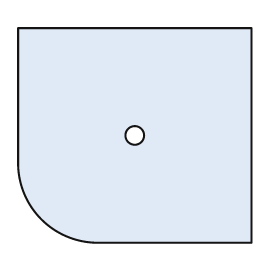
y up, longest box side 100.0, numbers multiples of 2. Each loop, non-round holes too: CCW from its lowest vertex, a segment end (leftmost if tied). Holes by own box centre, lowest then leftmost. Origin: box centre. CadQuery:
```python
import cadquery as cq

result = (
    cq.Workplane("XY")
    .moveTo(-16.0, -46.0)
    .lineTo(50.0, -46.0)
    .lineTo(50.0, 46.0)
    .lineTo(-50.0, 46.0)
    .lineTo(-50.0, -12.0)
    .threePointArc((-40.0, -36.0), (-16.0, -46.0))
    .close()
    .moveTo(0.0, 0.0)
    .circle(4.0)
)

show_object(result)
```